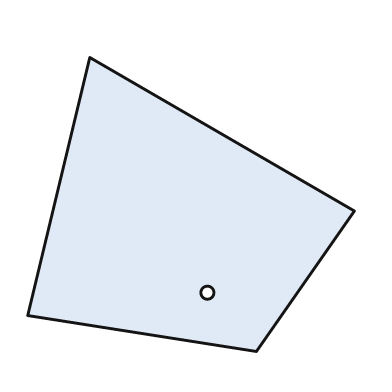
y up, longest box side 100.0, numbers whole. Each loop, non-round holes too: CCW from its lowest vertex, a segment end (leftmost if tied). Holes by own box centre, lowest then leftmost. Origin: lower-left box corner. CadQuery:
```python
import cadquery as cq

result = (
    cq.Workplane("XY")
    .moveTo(70.0, 0.0)
    .lineTo(100.0, 43.0)
    .lineTo(19.0, 90.0)
    .lineTo(0.0, 11.0)
    .close()
    .moveTo(55.0, 18.0)
    .circle(2.0)
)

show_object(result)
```